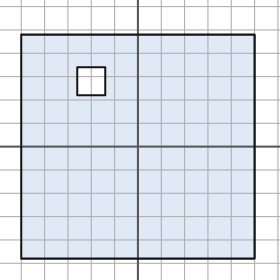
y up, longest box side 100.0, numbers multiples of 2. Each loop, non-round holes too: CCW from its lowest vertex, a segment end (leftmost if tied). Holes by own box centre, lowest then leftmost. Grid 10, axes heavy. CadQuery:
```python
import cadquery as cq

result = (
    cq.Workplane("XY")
    .moveTo(-50.0, -48.0)
    .lineTo(50.0, -48.0)
    .lineTo(50.0, 48.0)
    .lineTo(-50.0, 48.0)
    .close()
    .moveTo(-26.0, 22.0)
    .lineTo(-14.0, 22.0)
    .lineTo(-14.0, 34.0)
    .lineTo(-26.0, 34.0)
    .close()
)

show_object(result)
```